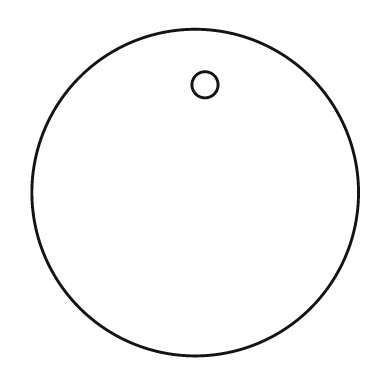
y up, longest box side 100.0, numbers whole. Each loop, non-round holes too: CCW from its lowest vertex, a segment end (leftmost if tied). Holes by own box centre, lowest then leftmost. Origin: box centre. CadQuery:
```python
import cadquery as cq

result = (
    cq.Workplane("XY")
    .moveTo(0.0, 0.0)
    .circle(50.0)
    .moveTo(3.0, 33.0)
    .circle(4.0)
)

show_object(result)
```